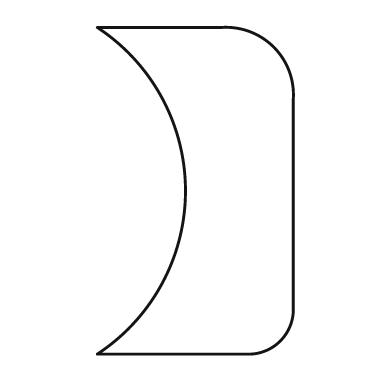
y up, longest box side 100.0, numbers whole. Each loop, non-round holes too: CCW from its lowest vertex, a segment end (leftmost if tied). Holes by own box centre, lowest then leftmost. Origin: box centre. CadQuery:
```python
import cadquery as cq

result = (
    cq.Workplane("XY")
    .moveTo(-30.0, -50.0)
    .lineTo(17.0, -50.0)
    .threePointArc((26.0, -46.0), (30.0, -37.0))
    .lineTo(30.0, 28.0)
    .threePointArc((24.0, 44.0), (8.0, 50.0))
    .lineTo(-30.0, 50.0)
    .threePointArc((-3.0, 0.0), (-30.0, -50.0))
    .close()
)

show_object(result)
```